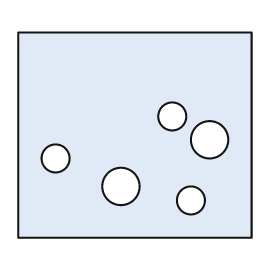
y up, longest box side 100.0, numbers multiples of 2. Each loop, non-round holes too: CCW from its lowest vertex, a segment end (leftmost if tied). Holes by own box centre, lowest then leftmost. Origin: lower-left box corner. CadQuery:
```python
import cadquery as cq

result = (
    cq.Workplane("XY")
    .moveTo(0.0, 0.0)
    .lineTo(100.0, 0.0)
    .lineTo(100.0, 88.0)
    .lineTo(0.0, 88.0)
    .close()
    .moveTo(74.0, 16.0)
    .circle(6.0)
    .moveTo(44.0, 22.0)
    .circle(8.0)
    .moveTo(16.0, 34.0)
    .circle(6.0)
    .moveTo(82.0, 42.0)
    .circle(8.0)
    .moveTo(66.0, 52.0)
    .circle(6.0)
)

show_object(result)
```